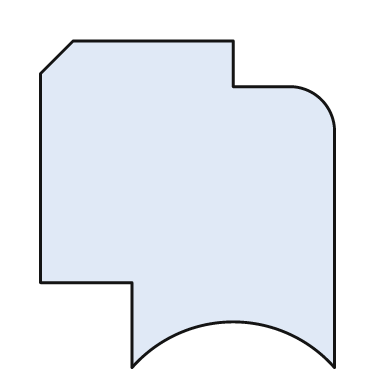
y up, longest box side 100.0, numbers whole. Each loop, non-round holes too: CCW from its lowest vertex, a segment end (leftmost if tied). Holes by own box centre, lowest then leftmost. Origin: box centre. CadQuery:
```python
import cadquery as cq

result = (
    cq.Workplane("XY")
    .moveTo(-17.0, -50.0)
    .threePointArc((14.0, -36.0), (45.0, -50.0))
    .lineTo(45.0, 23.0)
    .threePointArc((41.0, 32.0), (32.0, 36.0))
    .lineTo(14.0, 36.0)
    .lineTo(14.0, 50.0)
    .lineTo(-35.0, 50.0)
    .lineTo(-45.0, 40.0)
    .lineTo(-45.0, -24.0)
    .lineTo(-17.0, -24.0)
    .close()
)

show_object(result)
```